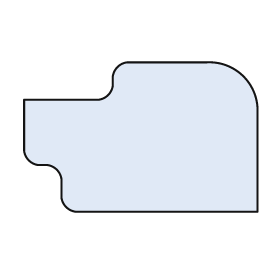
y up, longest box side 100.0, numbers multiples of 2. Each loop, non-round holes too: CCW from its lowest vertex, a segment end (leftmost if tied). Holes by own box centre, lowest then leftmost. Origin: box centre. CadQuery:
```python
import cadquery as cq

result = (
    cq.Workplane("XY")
    .moveTo(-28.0, -32.0)
    .lineTo(50.0, -32.0)
    .lineTo(50.0, 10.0)
    .threePointArc((44.0, 26.0), (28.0, 32.0))
    .lineTo(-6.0, 32.0)
    .threePointArc((-10.0, 30.0), (-12.0, 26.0))
    .lineTo(-12.0, 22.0)
    .threePointArc((-14.0, 18.0), (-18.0, 16.0))
    .lineTo(-50.0, 16.0)
    .lineTo(-50.0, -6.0)
    .threePointArc((-48.0, -10.0), (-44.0, -12.0))
    .lineTo(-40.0, -12.0)
    .threePointArc((-36.0, -14.0), (-34.0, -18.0))
    .lineTo(-34.0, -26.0)
    .threePointArc((-32.0, -30.0), (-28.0, -32.0))
    .close()
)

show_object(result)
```